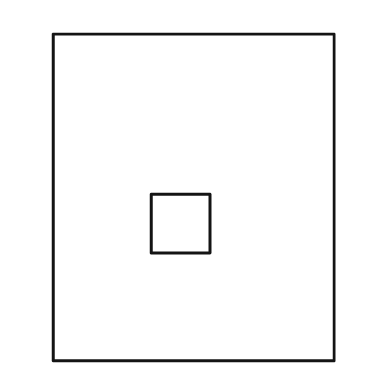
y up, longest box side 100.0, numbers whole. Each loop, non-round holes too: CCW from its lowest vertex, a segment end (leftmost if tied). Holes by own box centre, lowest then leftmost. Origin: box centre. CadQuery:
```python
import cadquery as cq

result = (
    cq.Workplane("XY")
    .moveTo(-43.0, -50.0)
    .lineTo(43.0, -50.0)
    .lineTo(43.0, 50.0)
    .lineTo(-43.0, 50.0)
    .close()
    .moveTo(-13.0, -17.0)
    .lineTo(5.0, -17.0)
    .lineTo(5.0, 1.0)
    .lineTo(-13.0, 1.0)
    .close()
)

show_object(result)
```